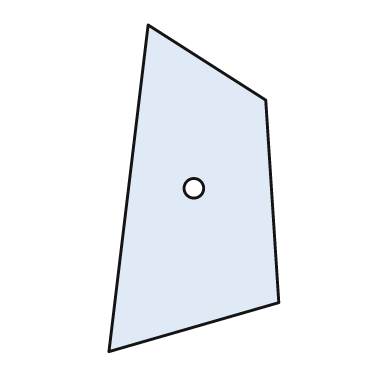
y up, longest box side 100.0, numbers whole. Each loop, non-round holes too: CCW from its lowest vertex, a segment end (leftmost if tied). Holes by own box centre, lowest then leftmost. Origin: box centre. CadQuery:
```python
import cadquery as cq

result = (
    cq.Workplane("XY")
    .moveTo(-26.0, -50.0)
    .lineTo(26.0, -35.0)
    .lineTo(22.0, 27.0)
    .lineTo(-14.0, 50.0)
    .close()
    .moveTo(0.0, 0.0)
    .circle(3.0)
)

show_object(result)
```